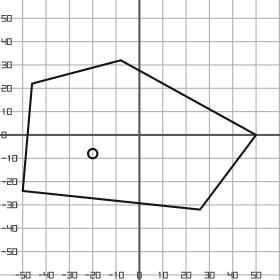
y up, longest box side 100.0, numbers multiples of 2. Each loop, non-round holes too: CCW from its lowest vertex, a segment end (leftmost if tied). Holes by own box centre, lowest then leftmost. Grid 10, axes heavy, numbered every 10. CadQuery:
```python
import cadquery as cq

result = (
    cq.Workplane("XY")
    .moveTo(26.0, -32.0)
    .lineTo(50.0, 0.0)
    .lineTo(-8.0, 32.0)
    .lineTo(-46.0, 22.0)
    .lineTo(-50.0, -24.0)
    .close()
    .moveTo(-20.0, -8.0)
    .circle(2.0)
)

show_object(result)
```